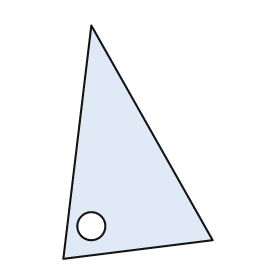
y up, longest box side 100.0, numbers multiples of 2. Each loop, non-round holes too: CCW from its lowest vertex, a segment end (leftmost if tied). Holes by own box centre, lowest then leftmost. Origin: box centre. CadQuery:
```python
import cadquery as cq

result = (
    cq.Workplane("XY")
    .moveTo(-32.0, -50.0)
    .lineTo(32.0, -42.0)
    .lineTo(-20.0, 50.0)
    .close()
    .moveTo(-20.0, -36.0)
    .circle(6.0)
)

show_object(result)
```